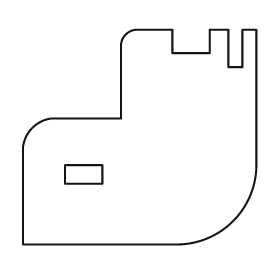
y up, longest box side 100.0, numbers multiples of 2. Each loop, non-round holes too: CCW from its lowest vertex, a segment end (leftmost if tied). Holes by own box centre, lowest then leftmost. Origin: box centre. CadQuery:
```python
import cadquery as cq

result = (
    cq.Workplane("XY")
    .moveTo(-50.0, -46.0)
    .lineTo(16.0, -46.0)
    .threePointArc((40.0, -36.0), (50.0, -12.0))
    .lineTo(50.0, 46.0)
    .lineTo(44.0, 46.0)
    .lineTo(44.0, 30.0)
    .lineTo(38.0, 30.0)
    .lineTo(38.0, 46.0)
    .lineTo(30.0, 46.0)
    .lineTo(30.0, 36.0)
    .lineTo(14.0, 36.0)
    .lineTo(14.0, 46.0)
    .lineTo(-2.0, 46.0)
    .threePointArc((-6.0, 44.0), (-8.0, 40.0))
    .lineTo(-8.0, 8.0)
    .lineTo(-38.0, 8.0)
    .threePointArc((-46.0, 4.0), (-50.0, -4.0))
    .close()
    .moveTo(-32.0, -20.0)
    .lineTo(-16.0, -20.0)
    .lineTo(-16.0, -12.0)
    .lineTo(-32.0, -12.0)
    .close()
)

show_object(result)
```